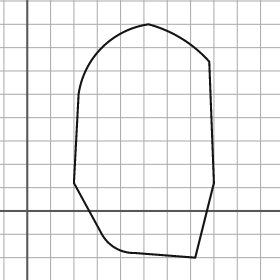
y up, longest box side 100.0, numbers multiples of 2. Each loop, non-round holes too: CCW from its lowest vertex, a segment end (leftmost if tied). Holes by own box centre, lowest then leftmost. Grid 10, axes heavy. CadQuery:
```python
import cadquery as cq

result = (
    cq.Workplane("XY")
    .moveTo(72.0, -20.0)
    .lineTo(80.0, 12.0)
    .lineTo(78.0, 64.0)
    .threePointArc((66.0, 74.0), (52.0, 80.0))
    .threePointArc((32.0, 70.0), (22.0, 50.0))
    .lineTo(20.0, 12.0)
    .lineTo(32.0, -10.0)
    .threePointArc((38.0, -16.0), (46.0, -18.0))
    .close()
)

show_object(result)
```